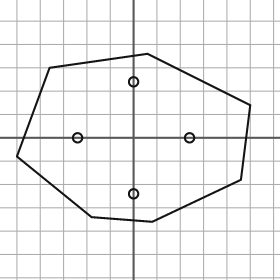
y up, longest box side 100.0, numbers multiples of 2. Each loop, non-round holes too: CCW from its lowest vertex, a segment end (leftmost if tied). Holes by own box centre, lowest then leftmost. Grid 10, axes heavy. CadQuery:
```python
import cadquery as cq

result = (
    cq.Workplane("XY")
    .moveTo(8.0, -36.0)
    .lineTo(46.0, -18.0)
    .lineTo(50.0, 14.0)
    .lineTo(6.0, 36.0)
    .lineTo(-36.0, 30.0)
    .lineTo(-50.0, -8.0)
    .lineTo(-18.0, -34.0)
    .close()
    .moveTo(0.0, -24.0)
    .circle(2.0)
    .moveTo(-24.0, 0.0)
    .circle(2.0)
    .moveTo(24.0, 0.0)
    .circle(2.0)
    .moveTo(0.0, 24.0)
    .circle(2.0)
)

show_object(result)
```